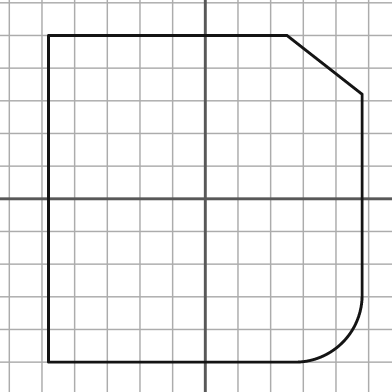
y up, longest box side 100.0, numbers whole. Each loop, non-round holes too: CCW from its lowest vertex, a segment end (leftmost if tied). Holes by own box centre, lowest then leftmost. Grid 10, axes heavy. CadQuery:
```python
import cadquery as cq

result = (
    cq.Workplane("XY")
    .moveTo(-48.0, -50.0)
    .lineTo(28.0, -50.0)
    .threePointArc((42.0, -44.0), (48.0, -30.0))
    .lineTo(48.0, 32.0)
    .lineTo(25.0, 50.0)
    .lineTo(-48.0, 50.0)
    .close()
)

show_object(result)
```